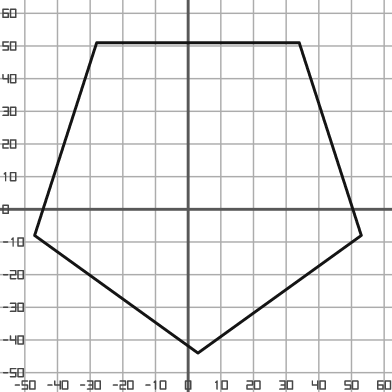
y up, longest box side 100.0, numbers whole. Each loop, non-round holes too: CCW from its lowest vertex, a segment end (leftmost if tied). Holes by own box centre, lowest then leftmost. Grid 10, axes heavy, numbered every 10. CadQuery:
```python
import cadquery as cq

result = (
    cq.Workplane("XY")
    .moveTo(3.0, -44.0)
    .lineTo(53.0, -8.0)
    .lineTo(34.0, 51.0)
    .lineTo(-28.0, 51.0)
    .lineTo(-47.0, -8.0)
    .close()
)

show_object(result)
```